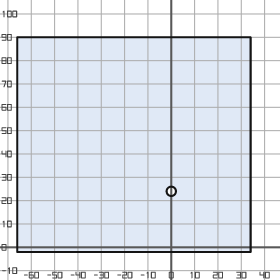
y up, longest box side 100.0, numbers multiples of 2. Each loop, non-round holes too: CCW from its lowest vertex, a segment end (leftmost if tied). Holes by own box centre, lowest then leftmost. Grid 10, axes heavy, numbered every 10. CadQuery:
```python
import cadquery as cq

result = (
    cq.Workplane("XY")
    .moveTo(-66.0, -2.0)
    .lineTo(34.0, -2.0)
    .lineTo(34.0, 90.0)
    .lineTo(-66.0, 90.0)
    .close()
    .moveTo(0.0, 24.0)
    .circle(2.0)
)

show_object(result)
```